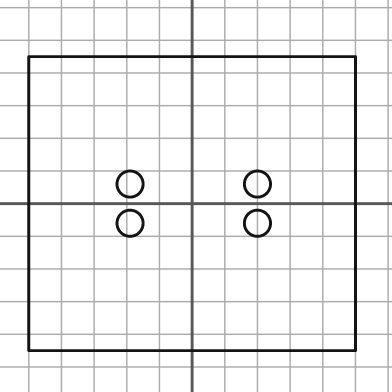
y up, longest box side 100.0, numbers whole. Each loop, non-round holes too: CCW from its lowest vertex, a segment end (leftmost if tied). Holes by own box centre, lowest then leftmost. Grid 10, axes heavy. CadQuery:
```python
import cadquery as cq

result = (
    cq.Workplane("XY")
    .moveTo(-50.0, -45.0)
    .lineTo(50.0, -45.0)
    .lineTo(50.0, 45.0)
    .lineTo(-50.0, 45.0)
    .close()
    .moveTo(-19.0, -6.0)
    .circle(4.0)
    .moveTo(20.0, -6.0)
    .circle(4.0)
    .moveTo(-19.0, 6.0)
    .circle(4.0)
    .moveTo(20.0, 6.0)
    .circle(4.0)
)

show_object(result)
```